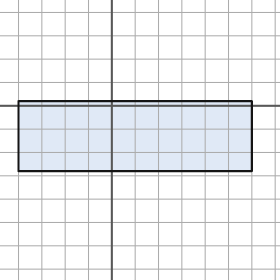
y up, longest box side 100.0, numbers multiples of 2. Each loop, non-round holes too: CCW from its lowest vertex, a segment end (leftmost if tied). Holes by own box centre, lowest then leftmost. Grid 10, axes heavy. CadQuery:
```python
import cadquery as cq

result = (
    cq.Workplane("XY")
    .moveTo(-40.0, -28.0)
    .lineTo(60.0, -28.0)
    .lineTo(60.0, 2.0)
    .lineTo(-40.0, 2.0)
    .close()
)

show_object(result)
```